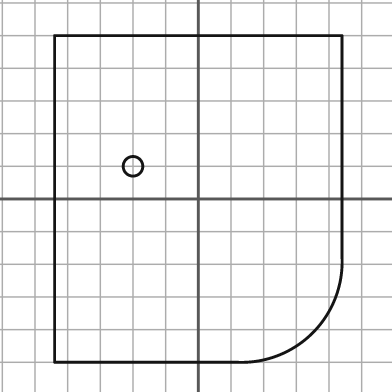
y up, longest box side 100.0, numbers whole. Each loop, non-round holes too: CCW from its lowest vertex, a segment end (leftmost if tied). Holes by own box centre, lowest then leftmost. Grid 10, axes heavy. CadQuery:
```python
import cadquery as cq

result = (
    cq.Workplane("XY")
    .moveTo(-44.0, -50.0)
    .lineTo(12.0, -50.0)
    .threePointArc((35.0, -41.0), (44.0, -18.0))
    .lineTo(44.0, 50.0)
    .lineTo(-44.0, 50.0)
    .close()
    .moveTo(-20.0, 10.0)
    .circle(3.0)
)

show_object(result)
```